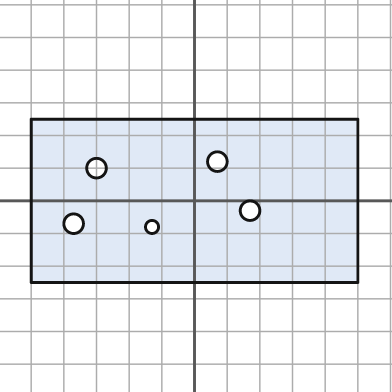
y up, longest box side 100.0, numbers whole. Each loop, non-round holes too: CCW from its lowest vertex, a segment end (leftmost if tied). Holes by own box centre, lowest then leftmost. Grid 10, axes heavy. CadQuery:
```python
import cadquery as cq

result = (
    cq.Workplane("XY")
    .moveTo(-50.0, -25.0)
    .lineTo(50.0, -25.0)
    .lineTo(50.0, 25.0)
    .lineTo(-50.0, 25.0)
    .close()
    .moveTo(-13.0, -8.0)
    .circle(2.0)
    .moveTo(-37.0, -7.0)
    .circle(3.0)
    .moveTo(17.0, -3.0)
    .circle(3.0)
    .moveTo(-30.0, 10.0)
    .circle(3.0)
    .moveTo(7.0, 12.0)
    .circle(3.0)
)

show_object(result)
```